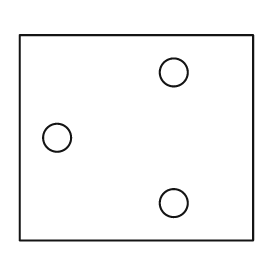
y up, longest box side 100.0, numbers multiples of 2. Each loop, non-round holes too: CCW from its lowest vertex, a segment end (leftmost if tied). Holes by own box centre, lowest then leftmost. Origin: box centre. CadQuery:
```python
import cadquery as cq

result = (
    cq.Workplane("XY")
    .moveTo(-50.0, -44.0)
    .lineTo(50.0, -44.0)
    .lineTo(50.0, 44.0)
    .lineTo(-50.0, 44.0)
    .close()
    .moveTo(16.0, -28.0)
    .circle(6.0)
    .moveTo(-34.0, 0.0)
    .circle(6.0)
    .moveTo(16.0, 28.0)
    .circle(6.0)
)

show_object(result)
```